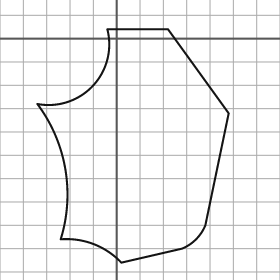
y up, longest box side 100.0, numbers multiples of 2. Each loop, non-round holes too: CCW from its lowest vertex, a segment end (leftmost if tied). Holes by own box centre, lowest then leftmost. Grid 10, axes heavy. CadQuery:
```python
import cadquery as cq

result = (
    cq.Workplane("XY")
    .moveTo(2.0, -96.0)
    .lineTo(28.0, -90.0)
    .threePointArc((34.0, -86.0), (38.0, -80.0))
    .lineTo(48.0, -32.0)
    .lineTo(22.0, 4.0)
    .lineTo(-4.0, 4.0)
    .threePointArc((-10.0, -20.0), (-34.0, -28.0))
    .threePointArc((-22.0, -56.0), (-24.0, -86.0))
    .threePointArc((-10.0, -88.0), (2.0, -96.0))
    .close()
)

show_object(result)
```